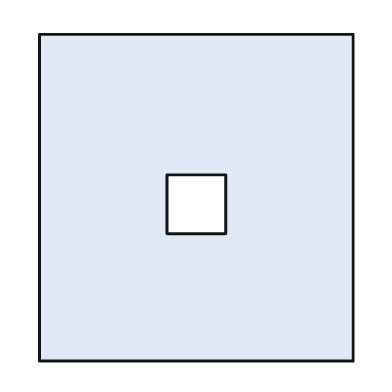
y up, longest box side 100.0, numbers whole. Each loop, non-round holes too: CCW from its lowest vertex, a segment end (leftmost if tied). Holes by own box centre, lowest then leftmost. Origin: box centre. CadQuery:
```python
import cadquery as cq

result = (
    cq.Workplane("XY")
    .moveTo(-48.0, -50.0)
    .lineTo(48.0, -50.0)
    .lineTo(48.0, 50.0)
    .lineTo(-48.0, 50.0)
    .close()
    .moveTo(-9.0, -11.0)
    .lineTo(9.0, -11.0)
    .lineTo(9.0, 7.0)
    .lineTo(-9.0, 7.0)
    .close()
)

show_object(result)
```